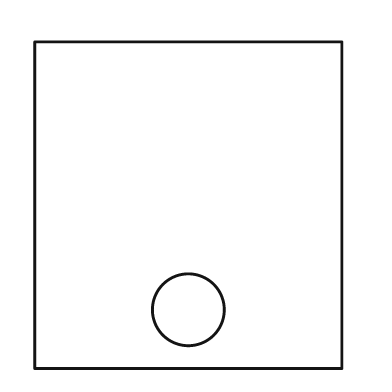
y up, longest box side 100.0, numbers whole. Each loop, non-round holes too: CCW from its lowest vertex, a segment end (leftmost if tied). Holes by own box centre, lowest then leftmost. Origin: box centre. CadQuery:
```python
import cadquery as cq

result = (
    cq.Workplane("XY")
    .moveTo(-47.0, -50.0)
    .lineTo(47.0, -50.0)
    .lineTo(47.0, 50.0)
    .lineTo(-47.0, 50.0)
    .close()
    .moveTo(0.0, -32.0)
    .circle(11.0)
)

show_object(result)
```